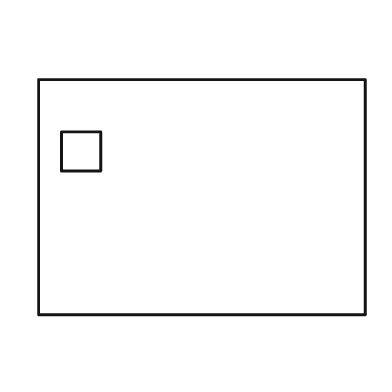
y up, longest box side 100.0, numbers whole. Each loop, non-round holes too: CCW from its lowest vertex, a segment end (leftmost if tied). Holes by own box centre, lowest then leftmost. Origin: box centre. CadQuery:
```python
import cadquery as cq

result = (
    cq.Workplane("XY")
    .moveTo(-50.0, -36.0)
    .lineTo(50.0, -36.0)
    .lineTo(50.0, 36.0)
    .lineTo(-50.0, 36.0)
    .close()
    .moveTo(-43.0, 8.0)
    .lineTo(-31.0, 8.0)
    .lineTo(-31.0, 20.0)
    .lineTo(-43.0, 20.0)
    .close()
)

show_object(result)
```